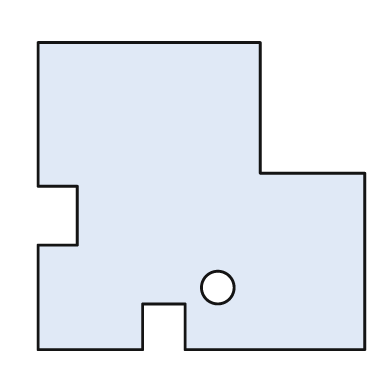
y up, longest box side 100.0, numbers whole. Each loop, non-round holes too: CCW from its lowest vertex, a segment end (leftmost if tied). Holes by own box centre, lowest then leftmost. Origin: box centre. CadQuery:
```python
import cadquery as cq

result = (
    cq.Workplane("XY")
    .moveTo(-50.0, -47.0)
    .lineTo(-18.0, -47.0)
    .lineTo(-18.0, -33.0)
    .lineTo(-5.0, -33.0)
    .lineTo(-5.0, -47.0)
    .lineTo(50.0, -47.0)
    .lineTo(50.0, 7.0)
    .lineTo(18.0, 7.0)
    .lineTo(18.0, 47.0)
    .lineTo(-50.0, 47.0)
    .lineTo(-50.0, 3.0)
    .lineTo(-38.0, 3.0)
    .lineTo(-38.0, -15.0)
    .lineTo(-50.0, -15.0)
    .close()
    .moveTo(5.0, -28.0)
    .circle(5.0)
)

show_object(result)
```